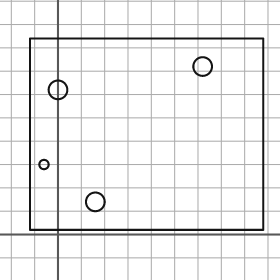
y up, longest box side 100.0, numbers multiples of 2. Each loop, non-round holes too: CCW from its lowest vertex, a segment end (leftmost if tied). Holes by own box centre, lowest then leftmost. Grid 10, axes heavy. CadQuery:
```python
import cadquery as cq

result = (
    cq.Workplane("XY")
    .moveTo(-12.0, 2.0)
    .lineTo(88.0, 2.0)
    .lineTo(88.0, 84.0)
    .lineTo(-12.0, 84.0)
    .close()
    .moveTo(16.0, 14.0)
    .circle(4.0)
    .moveTo(-6.0, 30.0)
    .circle(2.0)
    .moveTo(0.0, 62.0)
    .circle(4.0)
    .moveTo(62.0, 72.0)
    .circle(4.0)
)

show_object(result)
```